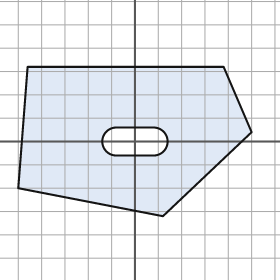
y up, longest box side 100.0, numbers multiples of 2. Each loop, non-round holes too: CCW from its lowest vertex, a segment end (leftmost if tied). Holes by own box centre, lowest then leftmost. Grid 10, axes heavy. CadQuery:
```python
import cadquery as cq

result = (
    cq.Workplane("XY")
    .moveTo(12.0, -32.0)
    .lineTo(50.0, 4.0)
    .lineTo(38.0, 32.0)
    .lineTo(-46.0, 32.0)
    .lineTo(-50.0, -20.0)
    .close()
    .moveTo(-8.0, -6.0)
    .lineTo(8.0, -6.0)
    .threePointArc((14.0, 0.0), (8.0, 6.0))
    .lineTo(-8.0, 6.0)
    .threePointArc((-14.0, 0.0), (-8.0, -6.0))
    .close()
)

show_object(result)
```